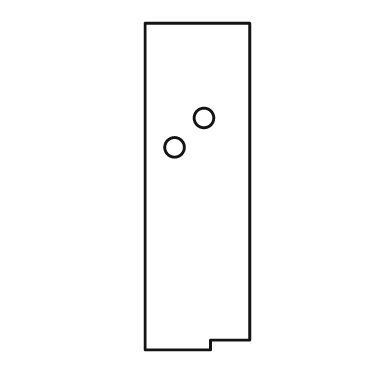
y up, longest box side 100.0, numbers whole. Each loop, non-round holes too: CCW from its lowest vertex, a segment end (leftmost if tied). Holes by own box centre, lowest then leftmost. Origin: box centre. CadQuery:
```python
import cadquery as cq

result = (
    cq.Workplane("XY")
    .moveTo(-16.0, -50.0)
    .lineTo(4.0, -50.0)
    .lineTo(4.0, -47.0)
    .lineTo(16.0, -47.0)
    .lineTo(16.0, 50.0)
    .lineTo(-16.0, 50.0)
    .close()
    .moveTo(-7.0, 12.0)
    .circle(3.0)
    .moveTo(2.0, 21.0)
    .circle(3.0)
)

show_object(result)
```